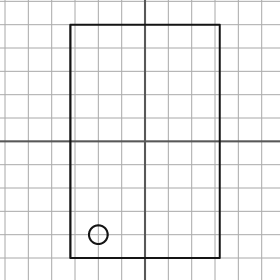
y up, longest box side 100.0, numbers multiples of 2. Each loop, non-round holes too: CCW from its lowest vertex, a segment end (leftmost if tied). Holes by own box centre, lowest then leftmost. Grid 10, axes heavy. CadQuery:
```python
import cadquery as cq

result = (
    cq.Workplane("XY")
    .moveTo(-32.0, -50.0)
    .lineTo(32.0, -50.0)
    .lineTo(32.0, 50.0)
    .lineTo(-32.0, 50.0)
    .close()
    .moveTo(-20.0, -40.0)
    .circle(4.0)
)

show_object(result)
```